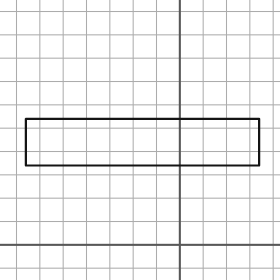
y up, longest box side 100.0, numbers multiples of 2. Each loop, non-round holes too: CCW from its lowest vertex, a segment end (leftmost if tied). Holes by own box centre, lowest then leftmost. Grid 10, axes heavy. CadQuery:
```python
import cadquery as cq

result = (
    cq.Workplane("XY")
    .moveTo(-66.0, 34.0)
    .lineTo(34.0, 34.0)
    .lineTo(34.0, 54.0)
    .lineTo(-66.0, 54.0)
    .close()
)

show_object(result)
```